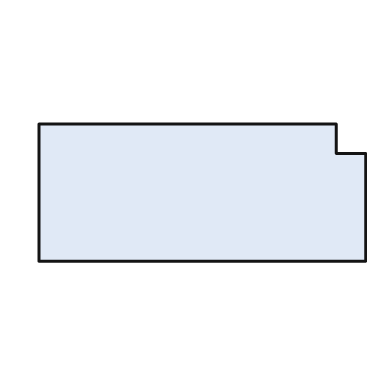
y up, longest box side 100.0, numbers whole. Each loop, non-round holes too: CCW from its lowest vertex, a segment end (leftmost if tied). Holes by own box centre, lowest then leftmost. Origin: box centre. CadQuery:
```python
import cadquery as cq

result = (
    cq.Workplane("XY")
    .moveTo(-50.0, -21.0)
    .lineTo(50.0, -21.0)
    .lineTo(50.0, 12.0)
    .lineTo(41.0, 12.0)
    .lineTo(41.0, 21.0)
    .lineTo(-50.0, 21.0)
    .close()
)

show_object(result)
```